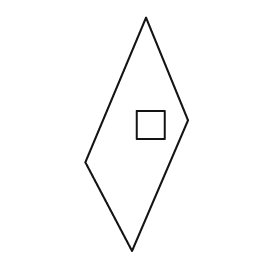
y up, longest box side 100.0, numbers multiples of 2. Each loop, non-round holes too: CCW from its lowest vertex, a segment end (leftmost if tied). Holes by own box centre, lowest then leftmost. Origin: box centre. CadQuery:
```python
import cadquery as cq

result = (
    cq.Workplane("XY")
    .moveTo(-2.0, -50.0)
    .lineTo(22.0, 6.0)
    .lineTo(4.0, 50.0)
    .lineTo(-22.0, -12.0)
    .close()
    .moveTo(0.0, -2.0)
    .lineTo(12.0, -2.0)
    .lineTo(12.0, 10.0)
    .lineTo(0.0, 10.0)
    .close()
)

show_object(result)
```